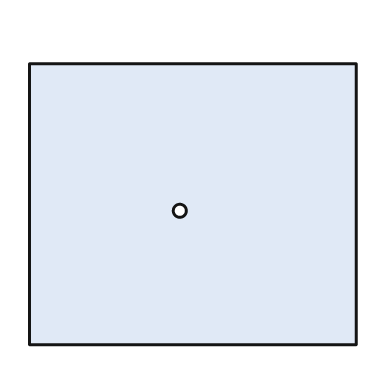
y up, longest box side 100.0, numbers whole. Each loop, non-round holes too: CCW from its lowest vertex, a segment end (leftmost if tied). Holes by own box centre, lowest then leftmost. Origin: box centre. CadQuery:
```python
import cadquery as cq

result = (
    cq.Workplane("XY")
    .moveTo(-50.0, -43.0)
    .lineTo(50.0, -43.0)
    .lineTo(50.0, 43.0)
    .lineTo(-50.0, 43.0)
    .close()
    .moveTo(-4.0, -2.0)
    .circle(2.0)
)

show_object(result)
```